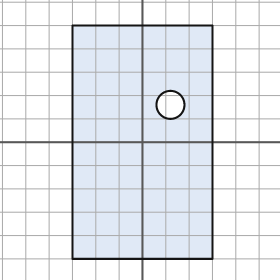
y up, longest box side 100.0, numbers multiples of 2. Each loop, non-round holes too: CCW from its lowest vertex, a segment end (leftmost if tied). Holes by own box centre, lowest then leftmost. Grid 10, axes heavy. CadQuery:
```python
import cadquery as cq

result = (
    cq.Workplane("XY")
    .moveTo(-30.0, -50.0)
    .lineTo(30.0, -50.0)
    .lineTo(30.0, 50.0)
    .lineTo(-30.0, 50.0)
    .close()
    .moveTo(12.0, 16.0)
    .circle(6.0)
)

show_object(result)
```